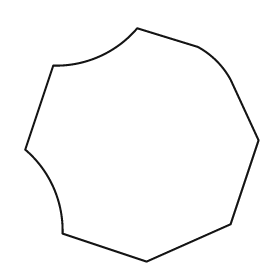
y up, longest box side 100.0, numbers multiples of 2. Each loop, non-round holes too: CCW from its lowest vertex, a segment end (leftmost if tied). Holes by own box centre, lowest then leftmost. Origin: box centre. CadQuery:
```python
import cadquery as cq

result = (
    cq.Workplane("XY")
    .moveTo(2.0, -50.0)
    .lineTo(38.0, -34.0)
    .lineTo(50.0, 2.0)
    .lineTo(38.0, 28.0)
    .threePointArc((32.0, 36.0), (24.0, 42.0))
    .lineTo(-2.0, 50.0)
    .threePointArc((-18.0, 38.0), (-38.0, 34.0))
    .lineTo(-50.0, -2.0)
    .threePointArc((-38.0, -18.0), (-34.0, -38.0))
    .close()
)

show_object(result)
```